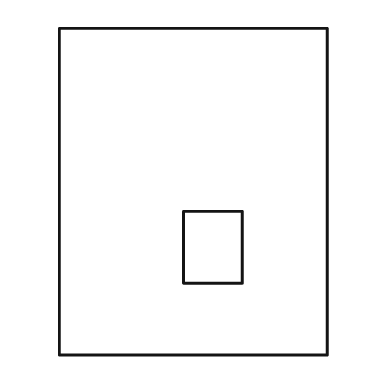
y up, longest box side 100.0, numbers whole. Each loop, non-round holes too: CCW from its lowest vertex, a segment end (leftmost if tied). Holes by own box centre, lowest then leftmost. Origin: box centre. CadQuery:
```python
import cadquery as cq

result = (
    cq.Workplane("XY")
    .moveTo(-41.0, -50.0)
    .lineTo(41.0, -50.0)
    .lineTo(41.0, 50.0)
    .lineTo(-41.0, 50.0)
    .close()
    .moveTo(-3.0, -28.0)
    .lineTo(15.0, -28.0)
    .lineTo(15.0, -6.0)
    .lineTo(-3.0, -6.0)
    .close()
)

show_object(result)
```